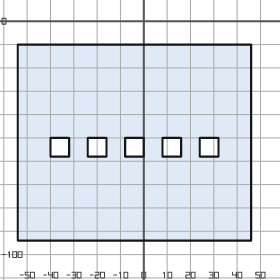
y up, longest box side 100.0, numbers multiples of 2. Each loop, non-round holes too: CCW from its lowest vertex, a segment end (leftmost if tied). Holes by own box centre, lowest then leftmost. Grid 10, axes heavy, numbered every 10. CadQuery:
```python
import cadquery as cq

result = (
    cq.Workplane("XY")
    .moveTo(-54.0, -94.0)
    .lineTo(46.0, -94.0)
    .lineTo(46.0, -10.0)
    .lineTo(-54.0, -10.0)
    .close()
    .moveTo(-40.0, -58.0)
    .lineTo(-32.0, -58.0)
    .lineTo(-32.0, -50.0)
    .lineTo(-40.0, -50.0)
    .close()
    .moveTo(-24.0, -58.0)
    .lineTo(-16.0, -58.0)
    .lineTo(-16.0, -50.0)
    .lineTo(-24.0, -50.0)
    .close()
    .moveTo(-8.0, -58.0)
    .lineTo(0.0, -58.0)
    .lineTo(0.0, -50.0)
    .lineTo(-8.0, -50.0)
    .close()
    .moveTo(8.0, -58.0)
    .lineTo(16.0, -58.0)
    .lineTo(16.0, -50.0)
    .lineTo(8.0, -50.0)
    .close()
    .moveTo(24.0, -58.0)
    .lineTo(32.0, -58.0)
    .lineTo(32.0, -50.0)
    .lineTo(24.0, -50.0)
    .close()
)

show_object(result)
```